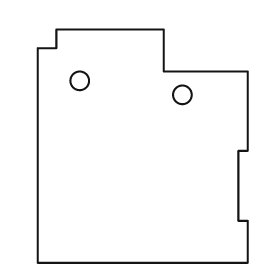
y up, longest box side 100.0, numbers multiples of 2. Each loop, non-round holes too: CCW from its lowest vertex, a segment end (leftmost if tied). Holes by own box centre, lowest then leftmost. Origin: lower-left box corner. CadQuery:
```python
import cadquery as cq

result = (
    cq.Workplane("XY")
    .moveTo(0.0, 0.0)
    .lineTo(90.0, 0.0)
    .lineTo(90.0, 18.0)
    .lineTo(86.0, 18.0)
    .lineTo(86.0, 48.0)
    .lineTo(90.0, 48.0)
    .lineTo(90.0, 82.0)
    .lineTo(54.0, 82.0)
    .lineTo(54.0, 100.0)
    .lineTo(8.0, 100.0)
    .lineTo(8.0, 92.0)
    .lineTo(0.0, 92.0)
    .close()
    .moveTo(62.0, 72.0)
    .circle(4.0)
    .moveTo(18.0, 78.0)
    .circle(4.0)
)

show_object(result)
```